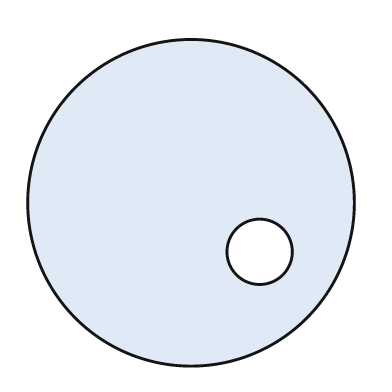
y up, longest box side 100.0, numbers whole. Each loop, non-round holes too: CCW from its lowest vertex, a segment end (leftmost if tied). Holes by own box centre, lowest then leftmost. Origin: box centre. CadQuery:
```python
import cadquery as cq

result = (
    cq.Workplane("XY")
    .moveTo(0.0, 0.0)
    .circle(50.0)
    .moveTo(21.0, -15.0)
    .circle(10.0)
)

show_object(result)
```